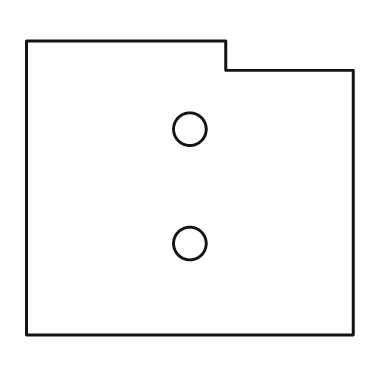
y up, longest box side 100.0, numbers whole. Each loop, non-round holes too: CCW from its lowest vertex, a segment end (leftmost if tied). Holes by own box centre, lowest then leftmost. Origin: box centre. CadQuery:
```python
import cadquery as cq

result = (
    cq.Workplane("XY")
    .moveTo(-50.0, -45.0)
    .lineTo(50.0, -45.0)
    .lineTo(50.0, 36.0)
    .lineTo(11.0, 36.0)
    .lineTo(11.0, 45.0)
    .lineTo(-50.0, 45.0)
    .close()
    .moveTo(0.0, -17.0)
    .circle(5.0)
    .moveTo(0.0, 18.0)
    .circle(5.0)
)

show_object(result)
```